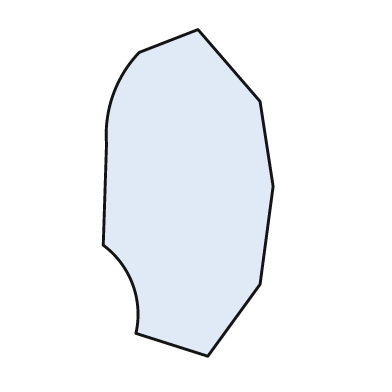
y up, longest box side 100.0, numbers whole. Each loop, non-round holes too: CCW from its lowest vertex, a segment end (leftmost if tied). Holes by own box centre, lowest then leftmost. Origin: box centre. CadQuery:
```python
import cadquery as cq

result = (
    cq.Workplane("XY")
    .moveTo(6.0, -50.0)
    .lineTo(22.0, -28.0)
    .lineTo(26.0, 2.0)
    .lineTo(22.0, 28.0)
    .lineTo(3.0, 50.0)
    .lineTo(-15.0, 43.0)
    .threePointArc((-23.0, 30.0), (-25.0, 15.0))
    .lineTo(-26.0, -16.0)
    .threePointArc((-17.0, -28.0), (-16.0, -43.0))
    .close()
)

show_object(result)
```